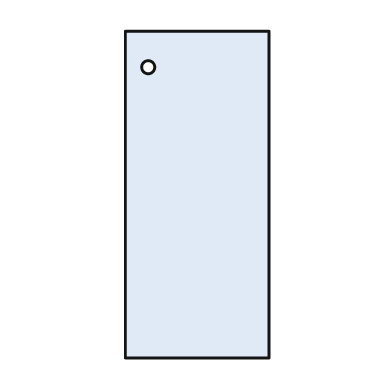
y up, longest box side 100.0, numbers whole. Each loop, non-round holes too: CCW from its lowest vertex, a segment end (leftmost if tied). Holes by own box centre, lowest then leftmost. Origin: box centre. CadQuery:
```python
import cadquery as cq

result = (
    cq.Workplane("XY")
    .moveTo(-22.0, -50.0)
    .lineTo(22.0, -50.0)
    .lineTo(22.0, 50.0)
    .lineTo(-22.0, 50.0)
    .close()
    .moveTo(-15.0, 39.0)
    .circle(2.0)
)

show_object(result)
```